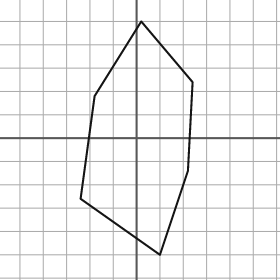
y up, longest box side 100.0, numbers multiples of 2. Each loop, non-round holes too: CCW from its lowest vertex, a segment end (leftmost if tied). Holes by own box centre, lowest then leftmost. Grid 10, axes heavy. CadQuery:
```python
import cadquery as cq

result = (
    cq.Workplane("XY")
    .moveTo(10.0, -50.0)
    .lineTo(22.0, -14.0)
    .lineTo(24.0, 24.0)
    .lineTo(2.0, 50.0)
    .lineTo(-18.0, 18.0)
    .lineTo(-24.0, -26.0)
    .close()
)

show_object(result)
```